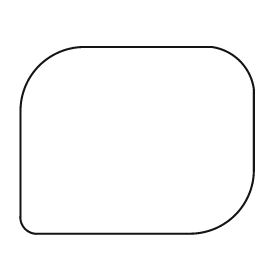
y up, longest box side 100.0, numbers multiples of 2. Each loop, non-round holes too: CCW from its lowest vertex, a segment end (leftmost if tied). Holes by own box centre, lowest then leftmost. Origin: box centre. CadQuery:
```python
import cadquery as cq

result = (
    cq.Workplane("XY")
    .moveTo(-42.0, -40.0)
    .lineTo(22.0, -40.0)
    .threePointArc((42.0, -32.0), (50.0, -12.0))
    .lineTo(50.0, 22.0)
    .threePointArc((44.0, 34.0), (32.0, 40.0))
    .lineTo(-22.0, 40.0)
    .threePointArc((-42.0, 32.0), (-50.0, 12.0))
    .lineTo(-50.0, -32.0)
    .threePointArc((-48.0, -38.0), (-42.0, -40.0))
    .close()
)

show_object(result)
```